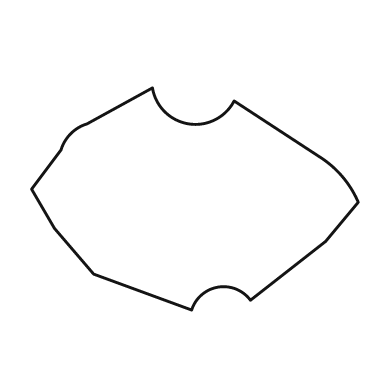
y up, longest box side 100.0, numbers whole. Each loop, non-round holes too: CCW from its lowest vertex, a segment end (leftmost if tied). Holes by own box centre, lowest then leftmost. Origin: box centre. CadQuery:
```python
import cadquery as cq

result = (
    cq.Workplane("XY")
    .moveTo(-1.0, -34.0)
    .threePointArc((7.0, -27.0), (17.0, -31.0))
    .lineTo(40.0, -13.0)
    .lineTo(50.0, -1.0)
    .threePointArc((45.0, 7.0), (38.0, 13.0))
    .lineTo(12.0, 30.0)
    .threePointArc((-2.0, 23.0), (-13.0, 34.0))
    .lineTo(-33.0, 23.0)
    .threePointArc((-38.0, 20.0), (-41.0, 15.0))
    .lineTo(-50.0, 3.0)
    .lineTo(-43.0, -9.0)
    .lineTo(-31.0, -23.0)
    .close()
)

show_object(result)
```